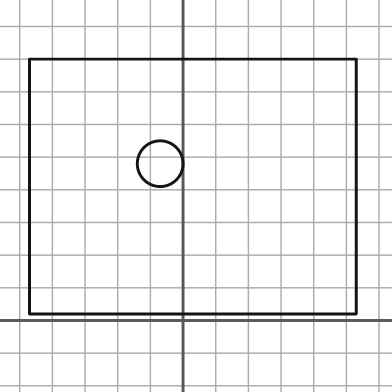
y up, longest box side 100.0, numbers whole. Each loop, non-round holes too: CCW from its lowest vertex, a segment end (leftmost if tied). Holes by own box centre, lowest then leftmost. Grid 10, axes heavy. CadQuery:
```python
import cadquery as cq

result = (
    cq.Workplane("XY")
    .moveTo(-47.0, 2.0)
    .lineTo(53.0, 2.0)
    .lineTo(53.0, 80.0)
    .lineTo(-47.0, 80.0)
    .close()
    .moveTo(-7.0, 48.0)
    .circle(7.0)
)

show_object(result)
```